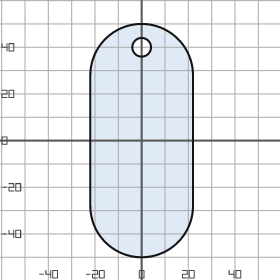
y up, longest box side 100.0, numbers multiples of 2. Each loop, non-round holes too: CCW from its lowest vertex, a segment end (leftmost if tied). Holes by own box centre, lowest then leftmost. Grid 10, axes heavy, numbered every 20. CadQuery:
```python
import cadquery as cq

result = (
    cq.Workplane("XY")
    .moveTo(-22.0, -28.0)
    .threePointArc((0.0, -50.0), (22.0, -28.0))
    .lineTo(22.0, 28.0)
    .threePointArc((0.0, 50.0), (-22.0, 28.0))
    .close()
    .moveTo(0.0, 40.0)
    .circle(4.0)
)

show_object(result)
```